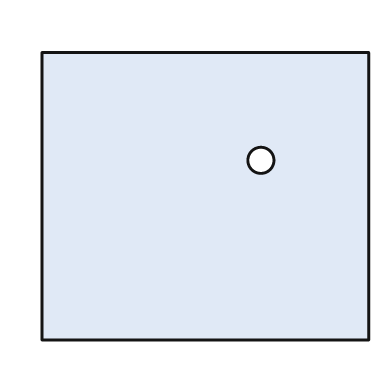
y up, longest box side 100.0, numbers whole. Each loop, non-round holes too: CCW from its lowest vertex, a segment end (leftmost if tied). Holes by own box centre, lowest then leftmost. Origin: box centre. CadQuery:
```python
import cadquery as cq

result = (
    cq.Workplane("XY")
    .moveTo(-50.0, -44.0)
    .lineTo(50.0, -44.0)
    .lineTo(50.0, 44.0)
    .lineTo(-50.0, 44.0)
    .close()
    .moveTo(17.0, 11.0)
    .circle(4.0)
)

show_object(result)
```